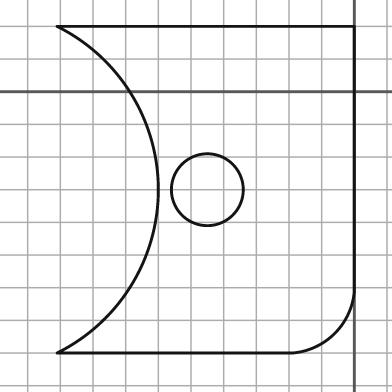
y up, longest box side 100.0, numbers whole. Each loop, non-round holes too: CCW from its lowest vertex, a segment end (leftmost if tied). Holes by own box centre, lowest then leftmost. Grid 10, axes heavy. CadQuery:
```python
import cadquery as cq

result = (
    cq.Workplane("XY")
    .moveTo(-91.0, -80.0)
    .lineTo(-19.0, -80.0)
    .threePointArc((-6.0, -74.0), (0.0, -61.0))
    .lineTo(0.0, 20.0)
    .lineTo(-91.0, 20.0)
    .threePointArc((-60.0, -30.0), (-91.0, -80.0))
    .close()
    .moveTo(-45.0, -30.0)
    .circle(11.0)
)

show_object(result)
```